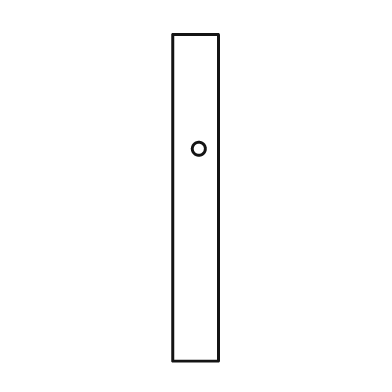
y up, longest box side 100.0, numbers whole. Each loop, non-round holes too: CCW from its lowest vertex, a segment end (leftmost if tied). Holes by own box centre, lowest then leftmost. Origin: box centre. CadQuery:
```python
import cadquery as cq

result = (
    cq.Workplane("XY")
    .moveTo(-7.0, -50.0)
    .lineTo(7.0, -50.0)
    .lineTo(7.0, 50.0)
    .lineTo(-7.0, 50.0)
    .close()
    .moveTo(1.0, 15.0)
    .circle(2.0)
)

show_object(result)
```